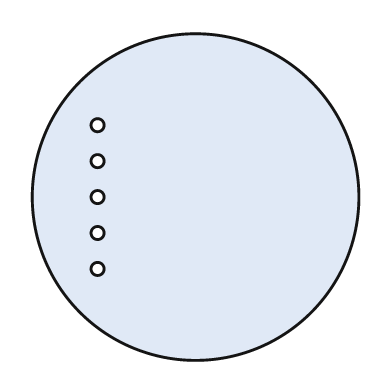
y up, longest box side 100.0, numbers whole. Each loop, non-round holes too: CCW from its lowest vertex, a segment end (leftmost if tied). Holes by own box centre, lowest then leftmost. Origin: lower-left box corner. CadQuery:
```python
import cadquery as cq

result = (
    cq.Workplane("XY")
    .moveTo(50.0, 50.0)
    .circle(50.0)
    .moveTo(20.0, 28.0)
    .circle(2.0)
    .moveTo(20.0, 39.0)
    .circle(2.0)
    .moveTo(20.0, 50.0)
    .circle(2.0)
    .moveTo(20.0, 61.0)
    .circle(2.0)
    .moveTo(20.0, 72.0)
    .circle(2.0)
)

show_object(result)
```